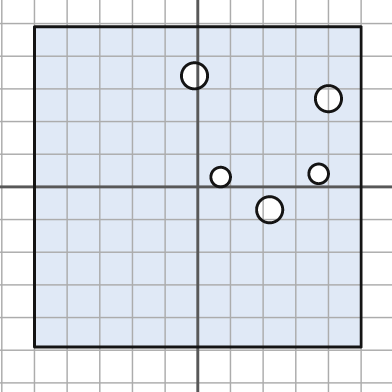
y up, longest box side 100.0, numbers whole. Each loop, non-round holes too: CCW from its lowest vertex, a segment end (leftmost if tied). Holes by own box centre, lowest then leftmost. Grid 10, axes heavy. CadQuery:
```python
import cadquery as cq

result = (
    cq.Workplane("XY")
    .moveTo(-50.0, -49.0)
    .lineTo(50.0, -49.0)
    .lineTo(50.0, 49.0)
    .lineTo(-50.0, 49.0)
    .close()
    .moveTo(22.0, -7.0)
    .circle(4.0)
    .moveTo(7.0, 3.0)
    .circle(3.0)
    .moveTo(37.0, 4.0)
    .circle(3.0)
    .moveTo(40.0, 27.0)
    .circle(4.0)
    .moveTo(-1.0, 34.0)
    .circle(4.0)
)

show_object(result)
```